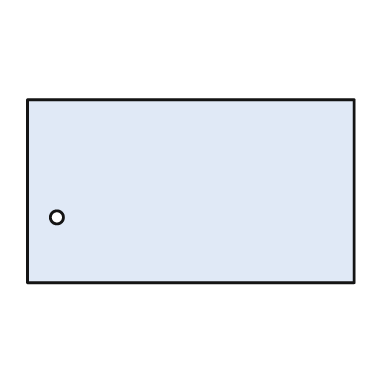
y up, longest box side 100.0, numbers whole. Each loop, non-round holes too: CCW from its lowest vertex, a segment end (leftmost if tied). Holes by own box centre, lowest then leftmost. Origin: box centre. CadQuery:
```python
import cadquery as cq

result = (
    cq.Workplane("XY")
    .moveTo(-50.0, -28.0)
    .lineTo(50.0, -28.0)
    .lineTo(50.0, 28.0)
    .lineTo(-50.0, 28.0)
    .close()
    .moveTo(-41.0, -8.0)
    .circle(2.0)
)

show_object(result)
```